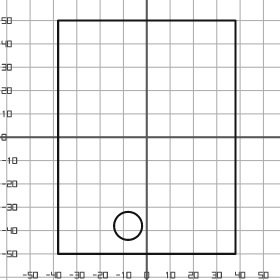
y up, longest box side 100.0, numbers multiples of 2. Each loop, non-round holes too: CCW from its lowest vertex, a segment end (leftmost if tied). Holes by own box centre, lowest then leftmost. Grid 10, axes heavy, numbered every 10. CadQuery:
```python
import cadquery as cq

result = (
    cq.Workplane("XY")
    .moveTo(-38.0, -50.0)
    .lineTo(38.0, -50.0)
    .lineTo(38.0, 50.0)
    .lineTo(-38.0, 50.0)
    .close()
    .moveTo(-8.0, -38.0)
    .circle(6.0)
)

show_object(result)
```